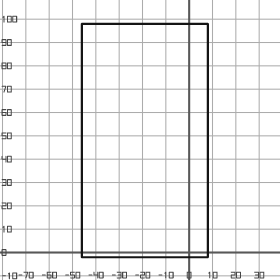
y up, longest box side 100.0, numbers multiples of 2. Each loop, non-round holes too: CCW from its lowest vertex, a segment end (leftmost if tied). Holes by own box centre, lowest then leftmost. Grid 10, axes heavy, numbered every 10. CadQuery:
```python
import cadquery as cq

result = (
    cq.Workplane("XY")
    .moveTo(-46.0, -2.0)
    .lineTo(8.0, -2.0)
    .lineTo(8.0, 98.0)
    .lineTo(-46.0, 98.0)
    .close()
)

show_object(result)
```